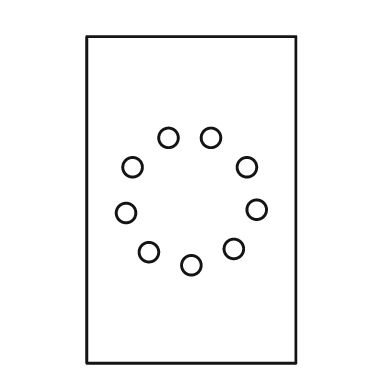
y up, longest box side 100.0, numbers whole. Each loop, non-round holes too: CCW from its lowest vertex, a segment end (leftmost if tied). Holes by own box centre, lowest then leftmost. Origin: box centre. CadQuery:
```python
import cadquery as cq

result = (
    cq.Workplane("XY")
    .moveTo(-32.0, -50.0)
    .lineTo(32.0, -50.0)
    .lineTo(32.0, 50.0)
    .lineTo(-32.0, 50.0)
    .close()
    .moveTo(0.0, -20.0)
    .circle(3.0)
    .moveTo(-13.0, -16.0)
    .circle(3.0)
    .moveTo(13.0, -15.0)
    .circle(3.0)
    .moveTo(-20.0, -4.0)
    .circle(3.0)
    .moveTo(20.0, -3.0)
    .circle(3.0)
    .moveTo(-18.0, 10.0)
    .circle(3.0)
    .moveTo(17.0, 10.0)
    .circle(3.0)
    .moveTo(-7.0, 19.0)
    .circle(3.0)
    .moveTo(6.0, 19.0)
    .circle(3.0)
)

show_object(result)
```